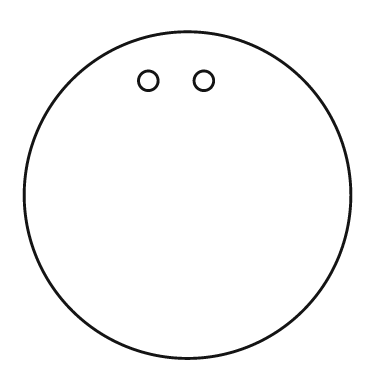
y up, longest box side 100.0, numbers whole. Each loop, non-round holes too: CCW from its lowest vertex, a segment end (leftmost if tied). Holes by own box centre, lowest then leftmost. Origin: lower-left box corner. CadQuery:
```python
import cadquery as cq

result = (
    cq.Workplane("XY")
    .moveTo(50.0, 50.0)
    .circle(50.0)
    .moveTo(38.0, 85.0)
    .circle(3.0)
    .moveTo(55.0, 85.0)
    .circle(3.0)
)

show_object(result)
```